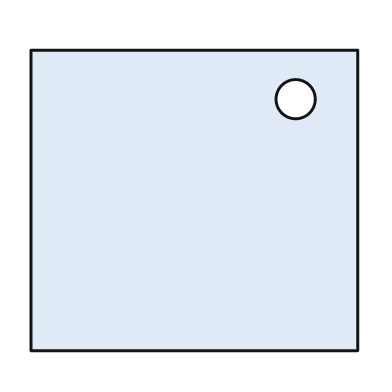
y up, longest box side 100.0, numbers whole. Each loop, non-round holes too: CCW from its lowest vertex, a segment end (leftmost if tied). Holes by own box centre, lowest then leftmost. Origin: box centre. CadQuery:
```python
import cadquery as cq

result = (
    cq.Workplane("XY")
    .moveTo(-50.0, -46.0)
    .lineTo(50.0, -46.0)
    .lineTo(50.0, 46.0)
    .lineTo(-50.0, 46.0)
    .close()
    .moveTo(31.0, 31.0)
    .circle(6.0)
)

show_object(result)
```